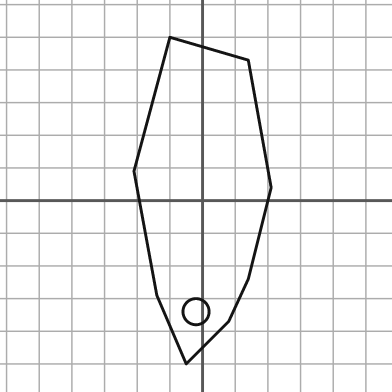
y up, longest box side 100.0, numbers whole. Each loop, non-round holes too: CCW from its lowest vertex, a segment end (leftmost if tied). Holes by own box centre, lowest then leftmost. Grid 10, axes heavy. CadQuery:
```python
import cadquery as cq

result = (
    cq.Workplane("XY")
    .moveTo(-5.0, -50.0)
    .lineTo(8.0, -37.0)
    .lineTo(14.0, -24.0)
    .lineTo(21.0, 4.0)
    .lineTo(14.0, 43.0)
    .lineTo(-10.0, 50.0)
    .lineTo(-21.0, 9.0)
    .lineTo(-14.0, -29.0)
    .close()
    .moveTo(-2.0, -34.0)
    .circle(4.0)
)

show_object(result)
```